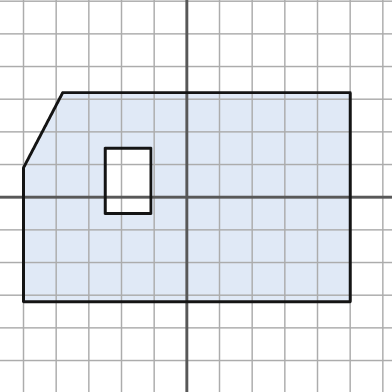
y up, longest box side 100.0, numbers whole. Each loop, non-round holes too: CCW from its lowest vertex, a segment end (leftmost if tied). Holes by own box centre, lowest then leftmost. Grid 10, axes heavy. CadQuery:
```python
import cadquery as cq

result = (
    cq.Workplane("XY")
    .moveTo(-50.0, -32.0)
    .lineTo(50.0, -32.0)
    .lineTo(50.0, 32.0)
    .lineTo(-38.0, 32.0)
    .lineTo(-50.0, 9.0)
    .close()
    .moveTo(-25.0, -5.0)
    .lineTo(-11.0, -5.0)
    .lineTo(-11.0, 15.0)
    .lineTo(-25.0, 15.0)
    .close()
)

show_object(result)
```